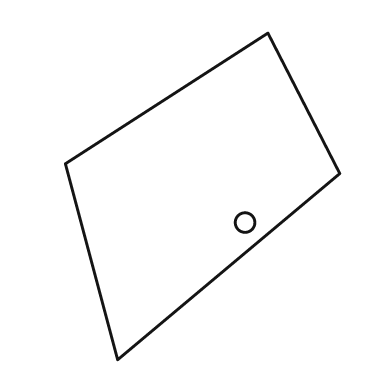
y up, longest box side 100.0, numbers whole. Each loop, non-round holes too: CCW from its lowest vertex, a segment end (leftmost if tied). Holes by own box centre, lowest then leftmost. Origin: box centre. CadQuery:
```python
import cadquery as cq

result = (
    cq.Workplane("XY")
    .moveTo(-26.0, -50.0)
    .lineTo(42.0, 7.0)
    .lineTo(20.0, 50.0)
    .lineTo(-42.0, 10.0)
    .close()
    .moveTo(13.0, -8.0)
    .circle(3.0)
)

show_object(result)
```